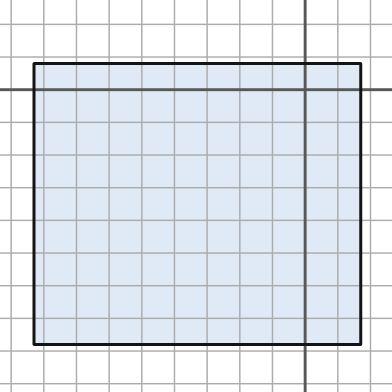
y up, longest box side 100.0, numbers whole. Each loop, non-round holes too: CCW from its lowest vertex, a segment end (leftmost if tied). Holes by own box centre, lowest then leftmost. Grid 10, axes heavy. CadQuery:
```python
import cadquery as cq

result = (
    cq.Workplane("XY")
    .moveTo(-83.0, -78.0)
    .lineTo(17.0, -78.0)
    .lineTo(17.0, 8.0)
    .lineTo(-83.0, 8.0)
    .close()
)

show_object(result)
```